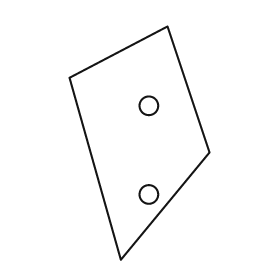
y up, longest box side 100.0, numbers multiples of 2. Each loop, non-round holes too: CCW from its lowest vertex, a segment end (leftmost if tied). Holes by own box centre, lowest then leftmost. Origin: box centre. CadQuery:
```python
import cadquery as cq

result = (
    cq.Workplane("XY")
    .moveTo(-8.0, -50.0)
    .lineTo(30.0, -4.0)
    .lineTo(12.0, 50.0)
    .lineTo(-30.0, 28.0)
    .close()
    .moveTo(4.0, -22.0)
    .circle(4.0)
    .moveTo(4.0, 16.0)
    .circle(4.0)
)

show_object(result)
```